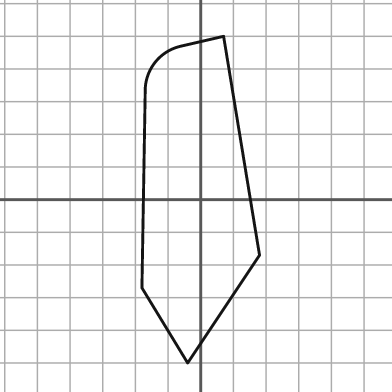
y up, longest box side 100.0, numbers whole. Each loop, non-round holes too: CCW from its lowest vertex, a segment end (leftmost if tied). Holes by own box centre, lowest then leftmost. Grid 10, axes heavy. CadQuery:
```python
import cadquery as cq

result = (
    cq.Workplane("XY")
    .moveTo(-4.0, -50.0)
    .lineTo(18.0, -17.0)
    .lineTo(7.0, 50.0)
    .lineTo(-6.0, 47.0)
    .threePointArc((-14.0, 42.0), (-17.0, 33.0))
    .lineTo(-18.0, -27.0)
    .close()
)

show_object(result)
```